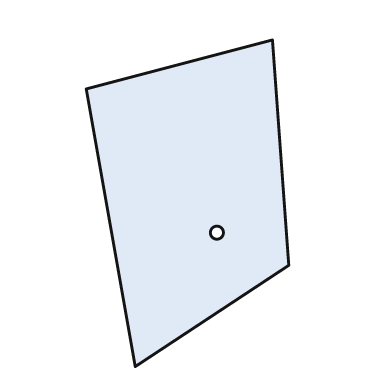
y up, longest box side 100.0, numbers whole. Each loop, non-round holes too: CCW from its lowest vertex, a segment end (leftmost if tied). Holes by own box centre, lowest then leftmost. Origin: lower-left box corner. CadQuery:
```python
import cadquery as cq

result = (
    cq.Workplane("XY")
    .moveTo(15.0, 0.0)
    .lineTo(62.0, 31.0)
    .lineTo(57.0, 100.0)
    .lineTo(0.0, 85.0)
    .close()
    .moveTo(40.0, 41.0)
    .circle(2.0)
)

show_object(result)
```